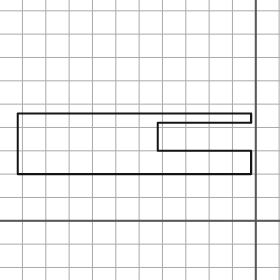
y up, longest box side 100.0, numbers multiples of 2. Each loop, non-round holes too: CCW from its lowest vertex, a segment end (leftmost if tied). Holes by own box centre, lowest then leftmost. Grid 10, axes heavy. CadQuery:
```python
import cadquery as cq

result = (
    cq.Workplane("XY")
    .moveTo(-102.0, 20.0)
    .lineTo(-2.0, 20.0)
    .lineTo(-2.0, 30.0)
    .lineTo(-42.0, 30.0)
    .lineTo(-42.0, 42.0)
    .lineTo(-2.0, 42.0)
    .lineTo(-2.0, 46.0)
    .lineTo(-102.0, 46.0)
    .close()
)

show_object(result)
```